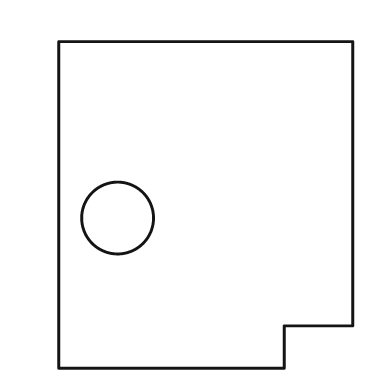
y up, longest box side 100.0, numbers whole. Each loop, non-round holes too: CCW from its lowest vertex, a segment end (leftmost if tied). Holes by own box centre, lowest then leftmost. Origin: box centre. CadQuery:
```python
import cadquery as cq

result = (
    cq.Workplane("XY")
    .moveTo(-45.0, -50.0)
    .lineTo(24.0, -50.0)
    .lineTo(24.0, -37.0)
    .lineTo(45.0, -37.0)
    .lineTo(45.0, 50.0)
    .lineTo(-45.0, 50.0)
    .close()
    .moveTo(-27.0, -4.0)
    .circle(11.0)
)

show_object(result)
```